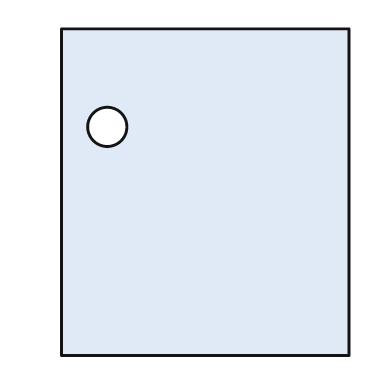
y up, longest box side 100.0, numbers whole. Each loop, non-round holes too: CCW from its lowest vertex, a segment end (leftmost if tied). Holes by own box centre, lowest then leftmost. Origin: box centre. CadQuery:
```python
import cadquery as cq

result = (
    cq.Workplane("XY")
    .moveTo(-44.0, -50.0)
    .lineTo(44.0, -50.0)
    .lineTo(44.0, 50.0)
    .lineTo(-44.0, 50.0)
    .close()
    .moveTo(-30.0, 20.0)
    .circle(6.0)
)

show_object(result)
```